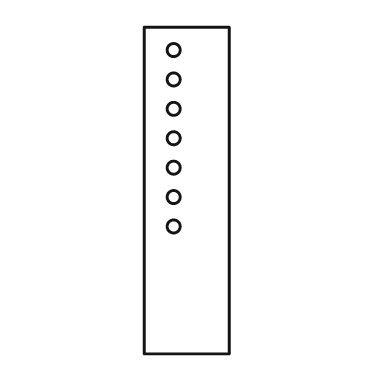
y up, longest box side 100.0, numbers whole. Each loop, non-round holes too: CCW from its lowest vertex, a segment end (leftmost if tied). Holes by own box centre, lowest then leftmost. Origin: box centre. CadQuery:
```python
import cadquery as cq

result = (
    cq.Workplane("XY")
    .moveTo(-13.0, -50.0)
    .lineTo(13.0, -50.0)
    .lineTo(13.0, 50.0)
    .lineTo(-13.0, 50.0)
    .close()
    .moveTo(-4.0, -11.0)
    .circle(2.0)
    .moveTo(-4.0, -2.0)
    .circle(2.0)
    .moveTo(-4.0, 7.0)
    .circle(2.0)
    .moveTo(-4.0, 16.0)
    .circle(2.0)
    .moveTo(-4.0, 25.0)
    .circle(2.0)
    .moveTo(-4.0, 34.0)
    .circle(2.0)
    .moveTo(-4.0, 43.0)
    .circle(2.0)
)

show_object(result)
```